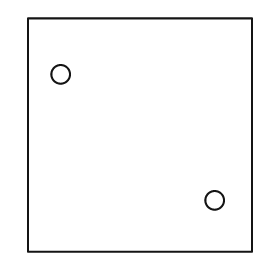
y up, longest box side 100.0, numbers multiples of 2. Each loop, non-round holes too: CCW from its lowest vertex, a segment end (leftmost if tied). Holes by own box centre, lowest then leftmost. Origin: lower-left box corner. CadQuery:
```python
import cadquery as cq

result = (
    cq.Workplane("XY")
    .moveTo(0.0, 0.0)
    .lineTo(96.0, 0.0)
    .lineTo(96.0, 100.0)
    .lineTo(0.0, 100.0)
    .close()
    .moveTo(80.0, 22.0)
    .circle(4.0)
    .moveTo(14.0, 76.0)
    .circle(4.0)
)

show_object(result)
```